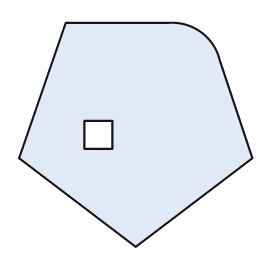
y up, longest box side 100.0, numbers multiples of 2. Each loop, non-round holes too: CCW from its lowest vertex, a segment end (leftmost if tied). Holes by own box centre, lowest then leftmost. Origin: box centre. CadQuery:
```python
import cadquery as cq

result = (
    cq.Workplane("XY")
    .moveTo(0.0, -48.0)
    .lineTo(50.0, -10.0)
    .lineTo(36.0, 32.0)
    .threePointArc((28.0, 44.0), (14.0, 48.0))
    .lineTo(-30.0, 48.0)
    .lineTo(-50.0, -10.0)
    .close()
    .moveTo(-22.0, -6.0)
    .lineTo(-10.0, -6.0)
    .lineTo(-10.0, 6.0)
    .lineTo(-22.0, 6.0)
    .close()
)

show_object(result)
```